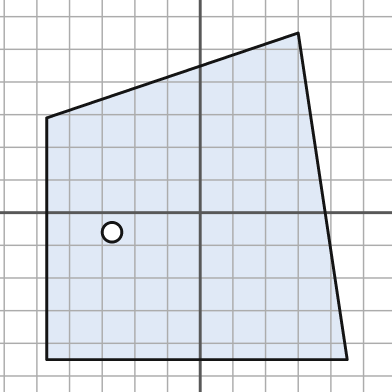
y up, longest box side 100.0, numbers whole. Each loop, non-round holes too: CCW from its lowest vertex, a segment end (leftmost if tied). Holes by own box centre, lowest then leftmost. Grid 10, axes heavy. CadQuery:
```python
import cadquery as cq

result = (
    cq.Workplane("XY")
    .moveTo(-47.0, -45.0)
    .lineTo(45.0, -45.0)
    .lineTo(30.0, 55.0)
    .lineTo(-47.0, 29.0)
    .close()
    .moveTo(-27.0, -6.0)
    .circle(3.0)
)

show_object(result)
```